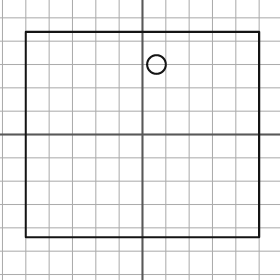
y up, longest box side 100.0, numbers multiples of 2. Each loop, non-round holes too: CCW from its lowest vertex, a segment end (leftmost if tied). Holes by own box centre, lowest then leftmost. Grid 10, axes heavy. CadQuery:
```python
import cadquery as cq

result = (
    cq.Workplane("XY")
    .moveTo(-50.0, -44.0)
    .lineTo(50.0, -44.0)
    .lineTo(50.0, 44.0)
    .lineTo(-50.0, 44.0)
    .close()
    .moveTo(6.0, 30.0)
    .circle(4.0)
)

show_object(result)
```